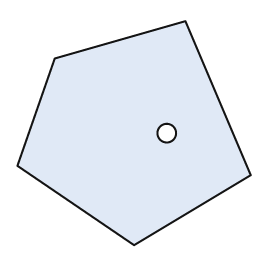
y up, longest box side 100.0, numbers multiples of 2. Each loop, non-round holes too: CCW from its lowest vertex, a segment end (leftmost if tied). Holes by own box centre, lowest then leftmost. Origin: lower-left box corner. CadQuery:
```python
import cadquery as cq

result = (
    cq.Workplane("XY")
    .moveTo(50.0, 0.0)
    .lineTo(100.0, 30.0)
    .lineTo(72.0, 96.0)
    .lineTo(16.0, 80.0)
    .lineTo(0.0, 34.0)
    .close()
    .moveTo(64.0, 48.0)
    .circle(4.0)
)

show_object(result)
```